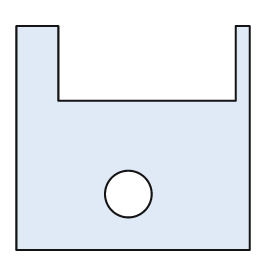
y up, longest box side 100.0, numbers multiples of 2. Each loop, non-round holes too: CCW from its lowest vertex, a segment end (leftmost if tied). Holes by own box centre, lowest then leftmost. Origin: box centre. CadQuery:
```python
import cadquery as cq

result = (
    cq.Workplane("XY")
    .moveTo(-50.0, -48.0)
    .lineTo(50.0, -48.0)
    .lineTo(50.0, 48.0)
    .lineTo(44.0, 48.0)
    .lineTo(44.0, 16.0)
    .lineTo(-32.0, 16.0)
    .lineTo(-32.0, 48.0)
    .lineTo(-50.0, 48.0)
    .close()
    .moveTo(-2.0, -24.0)
    .circle(10.0)
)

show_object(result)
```